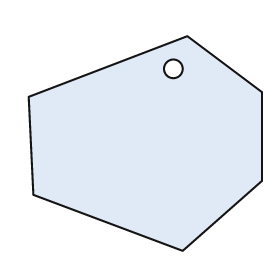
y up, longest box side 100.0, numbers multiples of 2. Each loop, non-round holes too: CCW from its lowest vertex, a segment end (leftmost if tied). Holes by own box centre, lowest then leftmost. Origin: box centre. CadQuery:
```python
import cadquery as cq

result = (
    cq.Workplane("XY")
    .moveTo(16.0, -46.0)
    .lineTo(50.0, -16.0)
    .lineTo(50.0, 22.0)
    .lineTo(18.0, 46.0)
    .lineTo(-50.0, 20.0)
    .lineTo(-48.0, -22.0)
    .close()
    .moveTo(12.0, 32.0)
    .circle(4.0)
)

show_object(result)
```